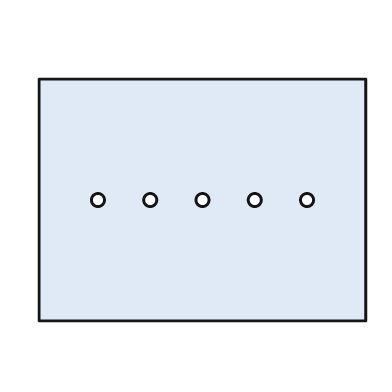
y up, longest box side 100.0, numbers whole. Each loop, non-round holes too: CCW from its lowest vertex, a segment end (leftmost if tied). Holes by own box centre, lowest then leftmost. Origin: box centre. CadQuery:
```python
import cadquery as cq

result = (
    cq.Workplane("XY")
    .moveTo(-50.0, -37.0)
    .lineTo(50.0, -37.0)
    .lineTo(50.0, 37.0)
    .lineTo(-50.0, 37.0)
    .close()
    .moveTo(-32.0, 0.0)
    .circle(2.0)
    .moveTo(-16.0, 0.0)
    .circle(2.0)
    .moveTo(0.0, 0.0)
    .circle(2.0)
    .moveTo(16.0, 0.0)
    .circle(2.0)
    .moveTo(32.0, 0.0)
    .circle(2.0)
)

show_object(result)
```